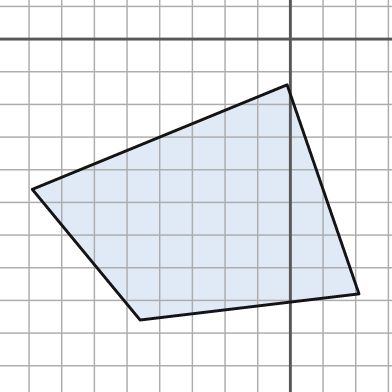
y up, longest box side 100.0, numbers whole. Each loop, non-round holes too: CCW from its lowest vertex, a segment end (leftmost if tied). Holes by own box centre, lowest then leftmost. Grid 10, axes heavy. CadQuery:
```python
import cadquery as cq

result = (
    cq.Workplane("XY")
    .moveTo(-46.0, -86.0)
    .lineTo(21.0, -78.0)
    .lineTo(-1.0, -14.0)
    .lineTo(-79.0, -46.0)
    .close()
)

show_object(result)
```